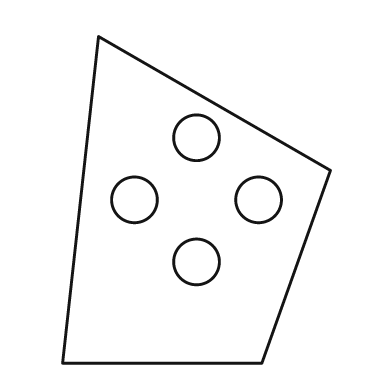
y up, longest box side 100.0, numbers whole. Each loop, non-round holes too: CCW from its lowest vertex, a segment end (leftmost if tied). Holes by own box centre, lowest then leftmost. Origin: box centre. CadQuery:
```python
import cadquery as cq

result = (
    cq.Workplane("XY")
    .moveTo(-41.0, -50.0)
    .lineTo(20.0, -50.0)
    .lineTo(41.0, 9.0)
    .lineTo(-30.0, 50.0)
    .close()
    .moveTo(0.0, -19.0)
    .circle(7.0)
    .moveTo(-19.0, 0.0)
    .circle(7.0)
    .moveTo(19.0, 0.0)
    .circle(7.0)
    .moveTo(0.0, 19.0)
    .circle(7.0)
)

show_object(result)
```